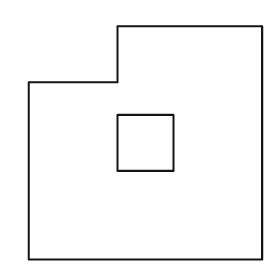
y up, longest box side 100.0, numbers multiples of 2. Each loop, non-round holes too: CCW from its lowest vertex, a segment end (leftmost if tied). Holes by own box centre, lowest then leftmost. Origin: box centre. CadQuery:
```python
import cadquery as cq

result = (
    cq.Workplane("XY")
    .moveTo(-50.0, -50.0)
    .lineTo(50.0, -50.0)
    .lineTo(50.0, 50.0)
    .lineTo(-12.0, 50.0)
    .lineTo(-12.0, 26.0)
    .lineTo(-50.0, 26.0)
    .close()
    .moveTo(-12.0, -12.0)
    .lineTo(12.0, -12.0)
    .lineTo(12.0, 12.0)
    .lineTo(-12.0, 12.0)
    .close()
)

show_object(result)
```